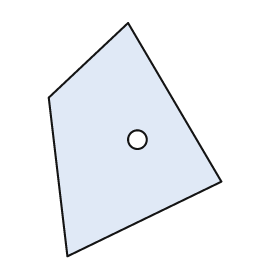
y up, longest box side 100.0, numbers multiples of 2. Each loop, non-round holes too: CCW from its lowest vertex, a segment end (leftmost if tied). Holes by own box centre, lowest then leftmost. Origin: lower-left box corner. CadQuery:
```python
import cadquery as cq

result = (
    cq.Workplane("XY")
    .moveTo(8.0, 0.0)
    .lineTo(74.0, 32.0)
    .lineTo(34.0, 100.0)
    .lineTo(0.0, 68.0)
    .close()
    .moveTo(38.0, 50.0)
    .circle(4.0)
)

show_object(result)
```